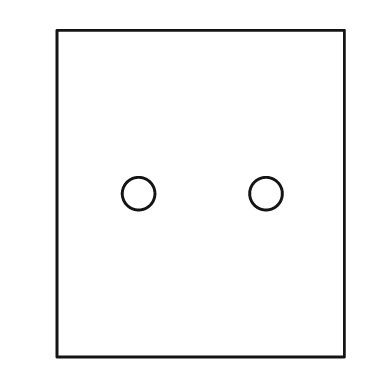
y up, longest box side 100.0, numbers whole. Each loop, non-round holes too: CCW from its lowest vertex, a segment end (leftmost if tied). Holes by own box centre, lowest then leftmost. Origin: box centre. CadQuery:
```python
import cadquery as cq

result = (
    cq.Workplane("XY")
    .moveTo(-44.0, -50.0)
    .lineTo(44.0, -50.0)
    .lineTo(44.0, 50.0)
    .lineTo(-44.0, 50.0)
    .close()
    .moveTo(-19.0, 0.0)
    .circle(5.0)
    .moveTo(20.0, 0.0)
    .circle(5.0)
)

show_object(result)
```